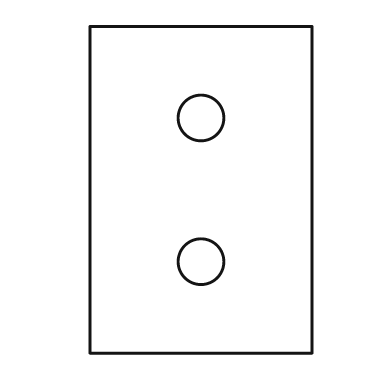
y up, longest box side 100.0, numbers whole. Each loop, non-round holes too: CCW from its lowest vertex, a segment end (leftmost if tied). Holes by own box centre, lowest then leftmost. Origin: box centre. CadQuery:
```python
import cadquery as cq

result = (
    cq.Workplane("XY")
    .moveTo(-34.0, -50.0)
    .lineTo(34.0, -50.0)
    .lineTo(34.0, 50.0)
    .lineTo(-34.0, 50.0)
    .close()
    .moveTo(0.0, -22.0)
    .circle(7.0)
    .moveTo(0.0, 22.0)
    .circle(7.0)
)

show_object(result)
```